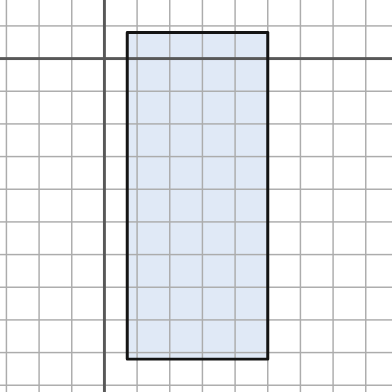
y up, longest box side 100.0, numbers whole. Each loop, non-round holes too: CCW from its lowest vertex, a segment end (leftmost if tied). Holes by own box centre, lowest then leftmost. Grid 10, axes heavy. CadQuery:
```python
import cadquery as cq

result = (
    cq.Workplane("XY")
    .moveTo(7.0, -92.0)
    .lineTo(50.0, -92.0)
    .lineTo(50.0, 8.0)
    .lineTo(7.0, 8.0)
    .close()
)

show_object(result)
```